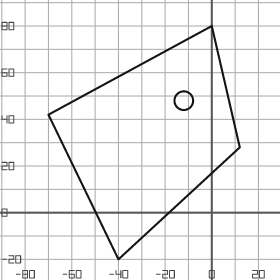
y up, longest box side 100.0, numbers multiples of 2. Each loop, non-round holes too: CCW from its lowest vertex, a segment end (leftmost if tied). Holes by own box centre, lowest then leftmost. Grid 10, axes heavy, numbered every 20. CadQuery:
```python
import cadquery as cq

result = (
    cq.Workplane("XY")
    .moveTo(-40.0, -20.0)
    .lineTo(12.0, 28.0)
    .lineTo(0.0, 80.0)
    .lineTo(-70.0, 42.0)
    .close()
    .moveTo(-12.0, 48.0)
    .circle(4.0)
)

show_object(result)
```